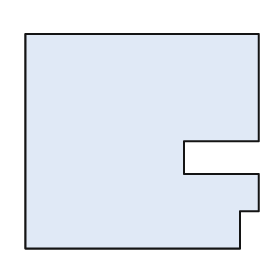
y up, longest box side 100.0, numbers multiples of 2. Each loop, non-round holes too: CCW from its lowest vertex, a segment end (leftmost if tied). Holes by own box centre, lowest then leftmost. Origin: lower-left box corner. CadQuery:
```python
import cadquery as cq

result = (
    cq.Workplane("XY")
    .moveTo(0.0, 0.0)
    .lineTo(92.0, 0.0)
    .lineTo(92.0, 16.0)
    .lineTo(100.0, 16.0)
    .lineTo(100.0, 32.0)
    .lineTo(68.0, 32.0)
    .lineTo(68.0, 46.0)
    .lineTo(100.0, 46.0)
    .lineTo(100.0, 92.0)
    .lineTo(0.0, 92.0)
    .close()
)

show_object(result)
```